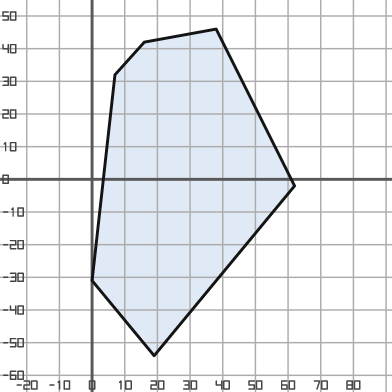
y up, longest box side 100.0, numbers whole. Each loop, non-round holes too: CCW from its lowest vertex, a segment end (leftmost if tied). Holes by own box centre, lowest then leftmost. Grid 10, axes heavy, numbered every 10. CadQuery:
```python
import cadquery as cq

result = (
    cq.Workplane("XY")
    .moveTo(19.0, -54.0)
    .lineTo(62.0, -2.0)
    .lineTo(38.0, 46.0)
    .lineTo(16.0, 42.0)
    .lineTo(7.0, 32.0)
    .lineTo(0.0, -31.0)
    .close()
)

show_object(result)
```